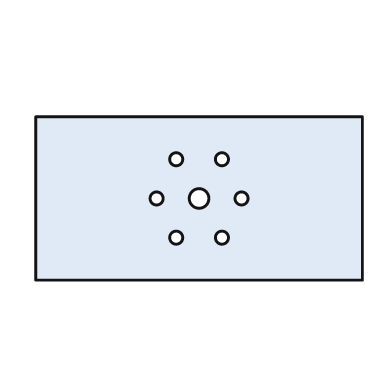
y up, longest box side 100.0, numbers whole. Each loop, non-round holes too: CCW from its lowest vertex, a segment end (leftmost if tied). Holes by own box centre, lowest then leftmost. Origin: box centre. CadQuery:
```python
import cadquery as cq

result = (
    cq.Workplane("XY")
    .moveTo(-50.0, -25.0)
    .lineTo(50.0, -25.0)
    .lineTo(50.0, 25.0)
    .lineTo(-50.0, 25.0)
    .close()
    .moveTo(-7.0, -12.0)
    .circle(2.0)
    .moveTo(7.0, -12.0)
    .circle(2.0)
    .moveTo(-13.0, 0.0)
    .circle(2.0)
    .moveTo(0.0, 0.0)
    .circle(3.0)
    .moveTo(13.0, 0.0)
    .circle(2.0)
    .moveTo(-7.0, 12.0)
    .circle(2.0)
    .moveTo(7.0, 12.0)
    .circle(2.0)
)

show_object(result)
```